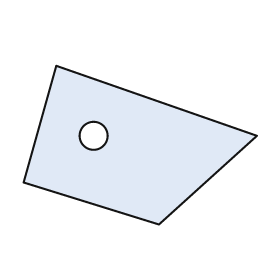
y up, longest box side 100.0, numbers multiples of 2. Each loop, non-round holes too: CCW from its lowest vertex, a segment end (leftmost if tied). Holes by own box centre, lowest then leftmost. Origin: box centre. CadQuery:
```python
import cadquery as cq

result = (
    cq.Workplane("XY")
    .moveTo(8.0, -34.0)
    .lineTo(50.0, 4.0)
    .lineTo(-36.0, 34.0)
    .lineTo(-50.0, -16.0)
    .close()
    .moveTo(-20.0, 4.0)
    .circle(6.0)
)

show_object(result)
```